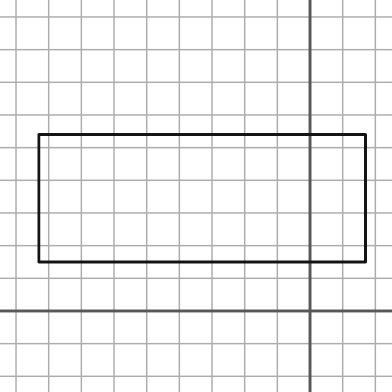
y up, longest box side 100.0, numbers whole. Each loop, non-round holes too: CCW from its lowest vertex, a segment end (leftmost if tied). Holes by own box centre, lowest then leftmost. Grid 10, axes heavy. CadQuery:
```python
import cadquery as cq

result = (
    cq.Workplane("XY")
    .moveTo(-83.0, 15.0)
    .lineTo(17.0, 15.0)
    .lineTo(17.0, 54.0)
    .lineTo(-83.0, 54.0)
    .close()
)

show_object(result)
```